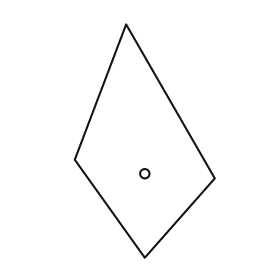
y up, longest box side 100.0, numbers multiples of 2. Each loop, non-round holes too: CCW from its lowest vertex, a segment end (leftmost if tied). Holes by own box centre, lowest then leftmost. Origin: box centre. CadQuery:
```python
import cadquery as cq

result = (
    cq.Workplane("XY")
    .moveTo(0.0, -50.0)
    .lineTo(30.0, -16.0)
    .lineTo(-8.0, 50.0)
    .lineTo(-30.0, -8.0)
    .close()
    .moveTo(0.0, -14.0)
    .circle(2.0)
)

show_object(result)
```